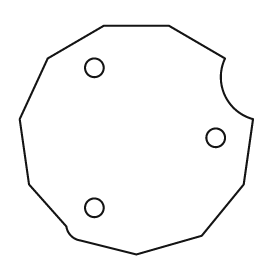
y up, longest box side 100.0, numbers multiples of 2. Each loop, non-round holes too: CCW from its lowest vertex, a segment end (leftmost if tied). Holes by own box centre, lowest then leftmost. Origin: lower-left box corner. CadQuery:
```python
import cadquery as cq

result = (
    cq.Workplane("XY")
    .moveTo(50.0, 0.0)
    .lineTo(78.0, 8.0)
    .lineTo(96.0, 30.0)
    .lineTo(100.0, 58.0)
    .threePointArc((88.0, 68.0), (88.0, 84.0))
    .lineTo(64.0, 98.0)
    .lineTo(36.0, 98.0)
    .lineTo(12.0, 84.0)
    .lineTo(0.0, 58.0)
    .lineTo(4.0, 30.0)
    .lineTo(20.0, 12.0)
    .threePointArc((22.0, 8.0), (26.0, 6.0))
    .close()
    .moveTo(32.0, 20.0)
    .circle(4.0)
    .moveTo(84.0, 50.0)
    .circle(4.0)
    .moveTo(32.0, 80.0)
    .circle(4.0)
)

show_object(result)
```